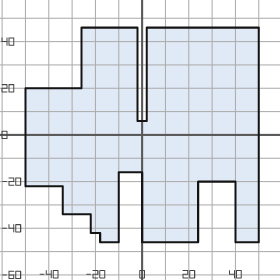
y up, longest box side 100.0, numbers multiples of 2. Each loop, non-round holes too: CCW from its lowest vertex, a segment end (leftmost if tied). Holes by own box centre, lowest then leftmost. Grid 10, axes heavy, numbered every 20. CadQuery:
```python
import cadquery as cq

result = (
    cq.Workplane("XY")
    .moveTo(-18.0, -46.0)
    .lineTo(-10.0, -46.0)
    .lineTo(-10.0, -16.0)
    .lineTo(0.0, -16.0)
    .lineTo(0.0, -46.0)
    .lineTo(24.0, -46.0)
    .lineTo(24.0, -20.0)
    .lineTo(40.0, -20.0)
    .lineTo(40.0, -46.0)
    .lineTo(50.0, -46.0)
    .lineTo(50.0, 46.0)
    .lineTo(2.0, 46.0)
    .lineTo(2.0, 6.0)
    .lineTo(-2.0, 6.0)
    .lineTo(-2.0, 46.0)
    .lineTo(-26.0, 46.0)
    .lineTo(-26.0, 20.0)
    .lineTo(-50.0, 20.0)
    .lineTo(-50.0, -22.0)
    .lineTo(-34.0, -22.0)
    .lineTo(-34.0, -34.0)
    .lineTo(-22.0, -34.0)
    .lineTo(-22.0, -42.0)
    .lineTo(-18.0, -42.0)
    .close()
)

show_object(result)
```